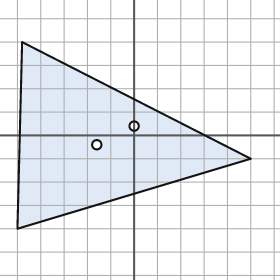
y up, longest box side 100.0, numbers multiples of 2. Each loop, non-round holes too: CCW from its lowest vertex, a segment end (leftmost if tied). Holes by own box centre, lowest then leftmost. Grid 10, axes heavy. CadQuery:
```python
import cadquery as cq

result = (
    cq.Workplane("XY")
    .moveTo(-50.0, -40.0)
    .lineTo(50.0, -10.0)
    .lineTo(-48.0, 40.0)
    .close()
    .moveTo(-16.0, -4.0)
    .circle(2.0)
    .moveTo(0.0, 4.0)
    .circle(2.0)
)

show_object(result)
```